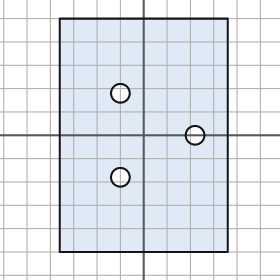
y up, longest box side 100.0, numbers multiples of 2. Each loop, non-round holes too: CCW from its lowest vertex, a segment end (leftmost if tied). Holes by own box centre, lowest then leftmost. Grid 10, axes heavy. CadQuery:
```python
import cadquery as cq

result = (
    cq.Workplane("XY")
    .moveTo(-36.0, -50.0)
    .lineTo(36.0, -50.0)
    .lineTo(36.0, 50.0)
    .lineTo(-36.0, 50.0)
    .close()
    .moveTo(-10.0, -18.0)
    .circle(4.0)
    .moveTo(22.0, 0.0)
    .circle(4.0)
    .moveTo(-10.0, 18.0)
    .circle(4.0)
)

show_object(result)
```